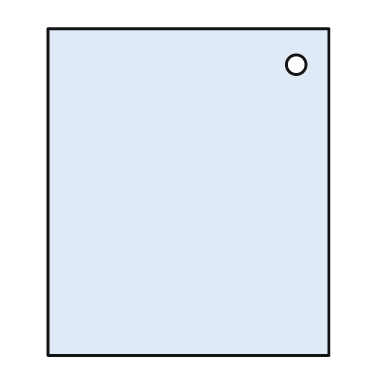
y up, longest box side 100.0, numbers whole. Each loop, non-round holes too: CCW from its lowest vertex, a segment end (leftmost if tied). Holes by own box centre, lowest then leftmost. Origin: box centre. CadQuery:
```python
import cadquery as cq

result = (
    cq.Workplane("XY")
    .moveTo(-43.0, -50.0)
    .lineTo(43.0, -50.0)
    .lineTo(43.0, 50.0)
    .lineTo(-43.0, 50.0)
    .close()
    .moveTo(33.0, 39.0)
    .circle(3.0)
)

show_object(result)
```